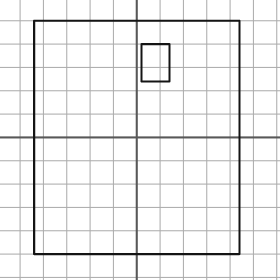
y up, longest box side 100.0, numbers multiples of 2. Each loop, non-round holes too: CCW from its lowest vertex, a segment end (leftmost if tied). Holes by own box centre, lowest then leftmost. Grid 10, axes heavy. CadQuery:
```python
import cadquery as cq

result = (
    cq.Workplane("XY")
    .moveTo(-44.0, -50.0)
    .lineTo(44.0, -50.0)
    .lineTo(44.0, 50.0)
    .lineTo(-44.0, 50.0)
    .close()
    .moveTo(2.0, 24.0)
    .lineTo(14.0, 24.0)
    .lineTo(14.0, 40.0)
    .lineTo(2.0, 40.0)
    .close()
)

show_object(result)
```